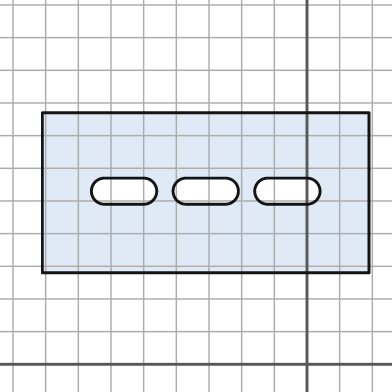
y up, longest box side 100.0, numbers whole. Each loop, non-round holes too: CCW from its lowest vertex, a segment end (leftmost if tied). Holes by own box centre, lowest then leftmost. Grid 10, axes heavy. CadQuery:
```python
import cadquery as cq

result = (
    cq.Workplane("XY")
    .moveTo(-81.0, 28.0)
    .lineTo(19.0, 28.0)
    .lineTo(19.0, 77.0)
    .lineTo(-81.0, 77.0)
    .close()
    .moveTo(-62.0, 49.0)
    .lineTo(-50.0, 49.0)
    .threePointArc((-46.0, 53.0), (-50.0, 57.0))
    .lineTo(-62.0, 57.0)
    .threePointArc((-66.0, 53.0), (-62.0, 49.0))
    .close()
    .moveTo(-37.0, 49.0)
    .lineTo(-25.0, 49.0)
    .threePointArc((-21.0, 53.0), (-25.0, 57.0))
    .lineTo(-37.0, 57.0)
    .threePointArc((-41.0, 53.0), (-37.0, 49.0))
    .close()
    .moveTo(-12.0, 49.0)
    .lineTo(0.0, 49.0)
    .threePointArc((4.0, 53.0), (0.0, 57.0))
    .lineTo(-12.0, 57.0)
    .threePointArc((-16.0, 53.0), (-12.0, 49.0))
    .close()
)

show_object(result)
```